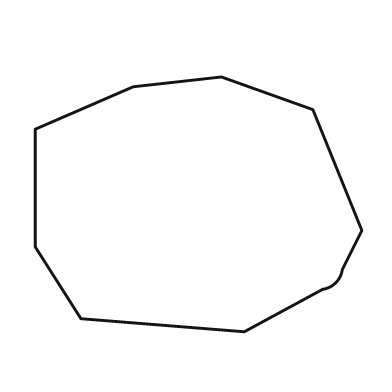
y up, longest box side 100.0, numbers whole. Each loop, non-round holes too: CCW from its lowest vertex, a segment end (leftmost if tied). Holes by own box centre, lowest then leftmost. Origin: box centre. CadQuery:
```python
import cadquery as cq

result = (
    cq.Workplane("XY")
    .moveTo(14.0, -39.0)
    .lineTo(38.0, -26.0)
    .threePointArc((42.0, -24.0), (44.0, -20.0))
    .lineTo(50.0, -8.0)
    .lineTo(35.0, 29.0)
    .lineTo(7.0, 39.0)
    .lineTo(-20.0, 36.0)
    .lineTo(-50.0, 23.0)
    .lineTo(-50.0, -13.0)
    .lineTo(-36.0, -35.0)
    .close()
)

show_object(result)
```